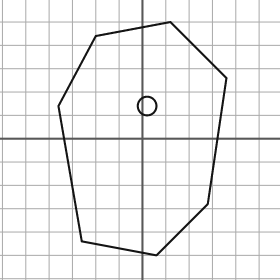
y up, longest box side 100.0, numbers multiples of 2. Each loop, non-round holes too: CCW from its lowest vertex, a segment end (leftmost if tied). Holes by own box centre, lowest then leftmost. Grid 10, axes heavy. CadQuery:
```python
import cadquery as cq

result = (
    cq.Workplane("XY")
    .moveTo(6.0, -50.0)
    .lineTo(28.0, -28.0)
    .lineTo(36.0, 26.0)
    .lineTo(12.0, 50.0)
    .lineTo(-20.0, 44.0)
    .lineTo(-36.0, 14.0)
    .lineTo(-26.0, -44.0)
    .close()
    .moveTo(2.0, 14.0)
    .circle(4.0)
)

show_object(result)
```